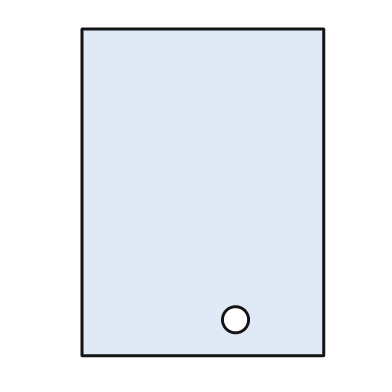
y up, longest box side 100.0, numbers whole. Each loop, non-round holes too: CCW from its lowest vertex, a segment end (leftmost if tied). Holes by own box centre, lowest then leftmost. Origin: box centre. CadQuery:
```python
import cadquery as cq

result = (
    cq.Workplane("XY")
    .moveTo(-37.0, -50.0)
    .lineTo(37.0, -50.0)
    .lineTo(37.0, 50.0)
    .lineTo(-37.0, 50.0)
    .close()
    .moveTo(10.0, -39.0)
    .circle(4.0)
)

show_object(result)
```